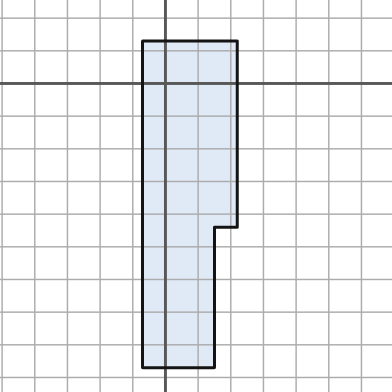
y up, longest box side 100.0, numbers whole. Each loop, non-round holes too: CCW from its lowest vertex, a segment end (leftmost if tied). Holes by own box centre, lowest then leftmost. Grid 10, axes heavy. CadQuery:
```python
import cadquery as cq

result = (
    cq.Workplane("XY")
    .moveTo(-7.0, -87.0)
    .lineTo(15.0, -87.0)
    .lineTo(15.0, -44.0)
    .lineTo(22.0, -44.0)
    .lineTo(22.0, 13.0)
    .lineTo(-7.0, 13.0)
    .close()
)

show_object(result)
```